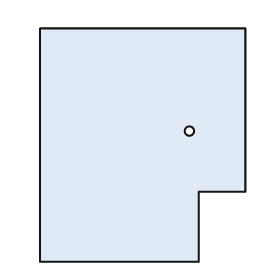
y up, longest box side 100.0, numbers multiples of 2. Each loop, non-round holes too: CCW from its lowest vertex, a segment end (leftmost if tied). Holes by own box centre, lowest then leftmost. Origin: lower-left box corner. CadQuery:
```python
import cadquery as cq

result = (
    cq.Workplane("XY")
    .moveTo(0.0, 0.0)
    .lineTo(68.0, 0.0)
    .lineTo(68.0, 30.0)
    .lineTo(88.0, 30.0)
    .lineTo(88.0, 100.0)
    .lineTo(0.0, 100.0)
    .close()
    .moveTo(64.0, 56.0)
    .circle(2.0)
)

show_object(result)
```